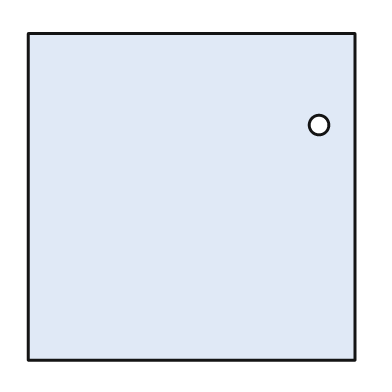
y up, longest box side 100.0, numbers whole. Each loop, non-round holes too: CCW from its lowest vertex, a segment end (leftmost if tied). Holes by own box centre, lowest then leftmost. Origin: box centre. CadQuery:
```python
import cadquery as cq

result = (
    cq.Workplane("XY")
    .moveTo(-50.0, -50.0)
    .lineTo(50.0, -50.0)
    .lineTo(50.0, 50.0)
    .lineTo(-50.0, 50.0)
    .close()
    .moveTo(39.0, 22.0)
    .circle(3.0)
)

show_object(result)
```